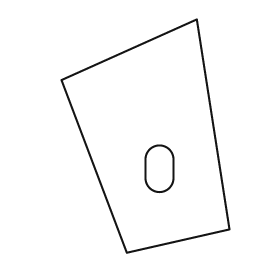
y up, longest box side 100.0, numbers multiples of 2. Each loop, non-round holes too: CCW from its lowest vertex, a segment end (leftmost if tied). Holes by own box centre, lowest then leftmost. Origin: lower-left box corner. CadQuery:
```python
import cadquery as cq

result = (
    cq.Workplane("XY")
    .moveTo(28.0, 0.0)
    .lineTo(72.0, 10.0)
    .lineTo(58.0, 100.0)
    .lineTo(0.0, 74.0)
    .close()
    .moveTo(36.0, 32.0)
    .threePointArc((42.0, 26.0), (48.0, 32.0))
    .lineTo(48.0, 40.0)
    .threePointArc((42.0, 46.0), (36.0, 40.0))
    .close()
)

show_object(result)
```